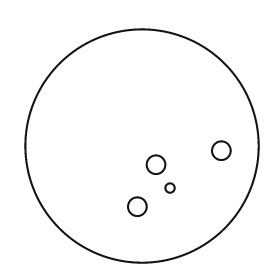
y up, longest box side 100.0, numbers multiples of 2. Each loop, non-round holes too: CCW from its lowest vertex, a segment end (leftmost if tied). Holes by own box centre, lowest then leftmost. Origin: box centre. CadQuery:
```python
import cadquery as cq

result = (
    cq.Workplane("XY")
    .moveTo(0.0, 0.0)
    .circle(50.0)
    .moveTo(-2.0, -26.0)
    .circle(4.0)
    .moveTo(12.0, -18.0)
    .circle(2.0)
    .moveTo(6.0, -8.0)
    .circle(4.0)
    .moveTo(34.0, -2.0)
    .circle(4.0)
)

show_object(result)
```